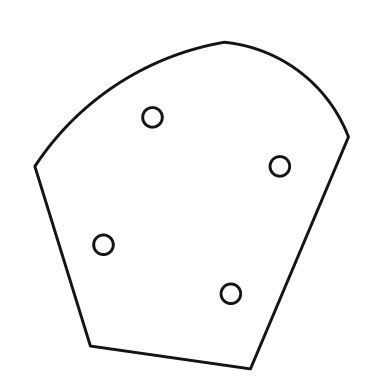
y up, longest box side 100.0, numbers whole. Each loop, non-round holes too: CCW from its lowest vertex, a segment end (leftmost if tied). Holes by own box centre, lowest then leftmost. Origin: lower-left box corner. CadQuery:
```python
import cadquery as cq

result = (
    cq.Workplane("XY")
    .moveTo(66.0, 0.0)
    .lineTo(96.0, 71.0)
    .threePointArc((81.0, 91.0), (58.0, 100.0))
    .threePointArc((25.0, 87.0), (0.0, 62.0))
    .lineTo(17.0, 7.0)
    .close()
    .moveTo(60.0, 23.0)
    .circle(3.0)
    .moveTo(21.0, 38.0)
    .circle(3.0)
    .moveTo(75.0, 62.0)
    .circle(3.0)
    .moveTo(36.0, 77.0)
    .circle(3.0)
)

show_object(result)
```